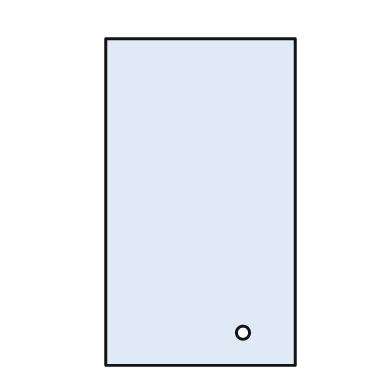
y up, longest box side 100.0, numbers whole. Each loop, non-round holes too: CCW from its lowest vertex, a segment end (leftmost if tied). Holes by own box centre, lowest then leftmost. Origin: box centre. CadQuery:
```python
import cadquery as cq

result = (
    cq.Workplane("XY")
    .moveTo(-29.0, -50.0)
    .lineTo(29.0, -50.0)
    .lineTo(29.0, 50.0)
    .lineTo(-29.0, 50.0)
    .close()
    .moveTo(13.0, -40.0)
    .circle(2.0)
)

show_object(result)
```